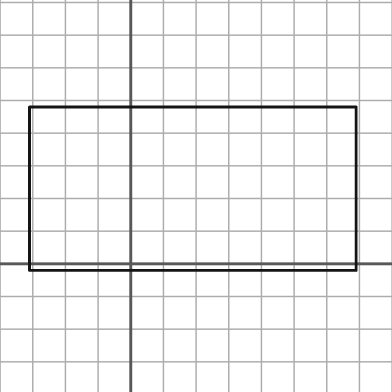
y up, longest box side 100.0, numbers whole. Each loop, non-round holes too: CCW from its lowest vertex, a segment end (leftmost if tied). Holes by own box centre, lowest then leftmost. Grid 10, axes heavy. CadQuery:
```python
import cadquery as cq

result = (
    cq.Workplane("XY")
    .moveTo(-31.0, -2.0)
    .lineTo(69.0, -2.0)
    .lineTo(69.0, 48.0)
    .lineTo(-31.0, 48.0)
    .close()
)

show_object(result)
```